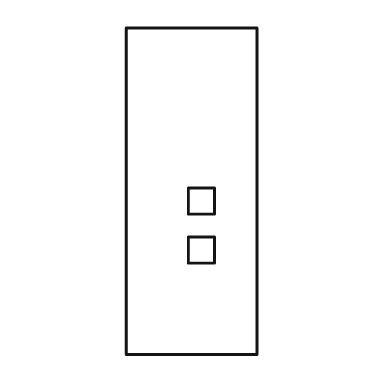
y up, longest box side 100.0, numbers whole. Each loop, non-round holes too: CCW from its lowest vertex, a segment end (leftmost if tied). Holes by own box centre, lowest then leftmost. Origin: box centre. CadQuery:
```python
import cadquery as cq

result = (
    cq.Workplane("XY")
    .moveTo(-20.0, -50.0)
    .lineTo(20.0, -50.0)
    .lineTo(20.0, 50.0)
    .lineTo(-20.0, 50.0)
    .close()
    .moveTo(-1.0, -22.0)
    .lineTo(7.0, -22.0)
    .lineTo(7.0, -14.0)
    .lineTo(-1.0, -14.0)
    .close()
    .moveTo(-1.0, -7.0)
    .lineTo(7.0, -7.0)
    .lineTo(7.0, 1.0)
    .lineTo(-1.0, 1.0)
    .close()
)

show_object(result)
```